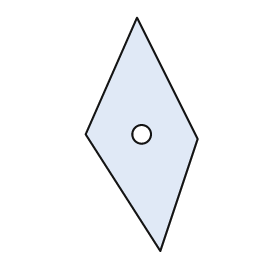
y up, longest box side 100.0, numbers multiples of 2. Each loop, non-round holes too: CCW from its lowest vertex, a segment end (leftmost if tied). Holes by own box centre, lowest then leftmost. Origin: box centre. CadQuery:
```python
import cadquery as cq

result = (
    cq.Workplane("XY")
    .moveTo(8.0, -50.0)
    .lineTo(24.0, -2.0)
    .lineTo(-2.0, 50.0)
    .lineTo(-24.0, 0.0)
    .close()
    .moveTo(0.0, 0.0)
    .circle(4.0)
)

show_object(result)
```